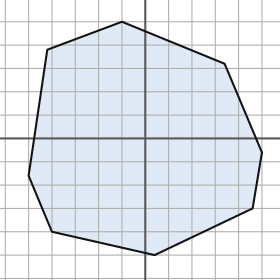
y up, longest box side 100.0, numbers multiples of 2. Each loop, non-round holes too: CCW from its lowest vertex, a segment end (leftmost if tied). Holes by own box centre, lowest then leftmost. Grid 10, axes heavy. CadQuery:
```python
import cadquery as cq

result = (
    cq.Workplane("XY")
    .moveTo(4.0, -50.0)
    .lineTo(46.0, -30.0)
    .lineTo(50.0, -6.0)
    .lineTo(34.0, 32.0)
    .lineTo(-10.0, 50.0)
    .lineTo(-42.0, 38.0)
    .lineTo(-50.0, -16.0)
    .lineTo(-40.0, -40.0)
    .close()
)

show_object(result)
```